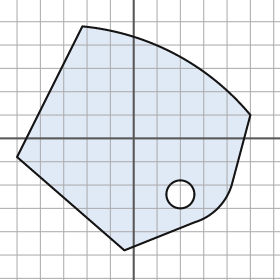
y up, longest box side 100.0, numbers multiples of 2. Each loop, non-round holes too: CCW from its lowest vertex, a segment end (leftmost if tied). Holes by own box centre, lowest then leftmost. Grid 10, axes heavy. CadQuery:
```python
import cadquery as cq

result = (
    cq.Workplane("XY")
    .moveTo(-4.0, -48.0)
    .lineTo(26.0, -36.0)
    .threePointArc((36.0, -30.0), (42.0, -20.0))
    .lineTo(50.0, 10.0)
    .threePointArc((18.0, 36.0), (-22.0, 48.0))
    .lineTo(-50.0, -8.0)
    .close()
    .moveTo(20.0, -24.0)
    .circle(6.0)
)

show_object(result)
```